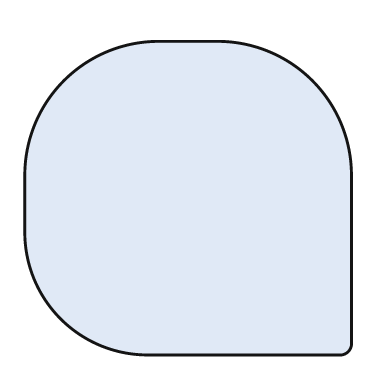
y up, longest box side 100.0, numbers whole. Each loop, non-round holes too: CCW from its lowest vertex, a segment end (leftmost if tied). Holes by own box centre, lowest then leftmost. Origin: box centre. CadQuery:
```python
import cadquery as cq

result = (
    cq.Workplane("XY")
    .moveTo(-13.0, -48.0)
    .lineTo(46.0, -48.0)
    .threePointArc((49.0, -47.0), (50.0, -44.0))
    .lineTo(50.0, 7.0)
    .threePointArc((38.0, 36.0), (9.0, 48.0))
    .lineTo(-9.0, 48.0)
    .threePointArc((-38.0, 36.0), (-50.0, 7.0))
    .lineTo(-50.0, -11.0)
    .threePointArc((-39.0, -37.0), (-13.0, -48.0))
    .close()
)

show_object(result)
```